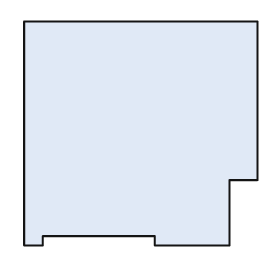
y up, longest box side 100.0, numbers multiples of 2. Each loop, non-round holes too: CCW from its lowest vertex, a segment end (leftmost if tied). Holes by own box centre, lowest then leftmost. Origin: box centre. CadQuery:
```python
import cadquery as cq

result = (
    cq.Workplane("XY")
    .moveTo(-50.0, -48.0)
    .lineTo(-42.0, -48.0)
    .lineTo(-42.0, -44.0)
    .lineTo(6.0, -44.0)
    .lineTo(6.0, -48.0)
    .lineTo(38.0, -48.0)
    .lineTo(38.0, -20.0)
    .lineTo(50.0, -20.0)
    .lineTo(50.0, 48.0)
    .lineTo(-50.0, 48.0)
    .close()
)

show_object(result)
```